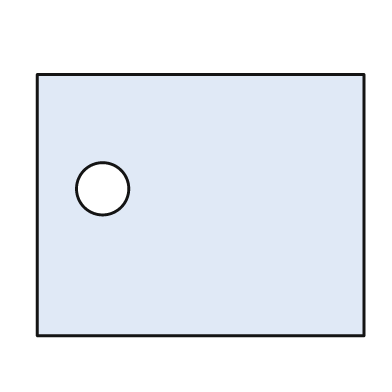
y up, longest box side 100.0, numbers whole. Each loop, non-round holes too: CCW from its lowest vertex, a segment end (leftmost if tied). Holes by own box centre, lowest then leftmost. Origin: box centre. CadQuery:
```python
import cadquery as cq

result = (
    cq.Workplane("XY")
    .moveTo(-50.0, -40.0)
    .lineTo(50.0, -40.0)
    .lineTo(50.0, 40.0)
    .lineTo(-50.0, 40.0)
    .close()
    .moveTo(-30.0, 5.0)
    .circle(8.0)
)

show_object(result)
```